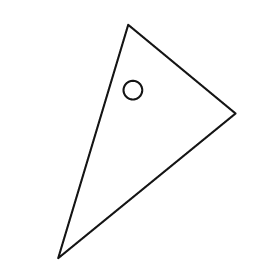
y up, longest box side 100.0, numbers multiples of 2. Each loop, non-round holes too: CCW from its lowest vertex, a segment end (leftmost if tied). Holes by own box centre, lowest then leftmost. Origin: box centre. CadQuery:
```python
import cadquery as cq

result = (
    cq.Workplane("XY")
    .moveTo(-38.0, -50.0)
    .lineTo(38.0, 12.0)
    .lineTo(-8.0, 50.0)
    .close()
    .moveTo(-6.0, 22.0)
    .circle(4.0)
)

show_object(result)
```